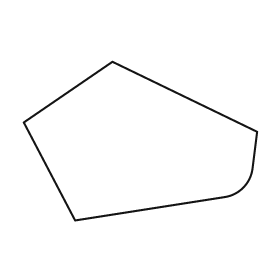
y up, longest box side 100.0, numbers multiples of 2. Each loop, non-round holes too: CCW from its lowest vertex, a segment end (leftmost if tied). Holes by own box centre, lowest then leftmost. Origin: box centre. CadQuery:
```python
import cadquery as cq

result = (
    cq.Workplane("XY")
    .moveTo(-28.0, -34.0)
    .lineTo(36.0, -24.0)
    .threePointArc((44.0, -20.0), (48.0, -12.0))
    .lineTo(50.0, 4.0)
    .lineTo(-12.0, 34.0)
    .lineTo(-50.0, 8.0)
    .close()
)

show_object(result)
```